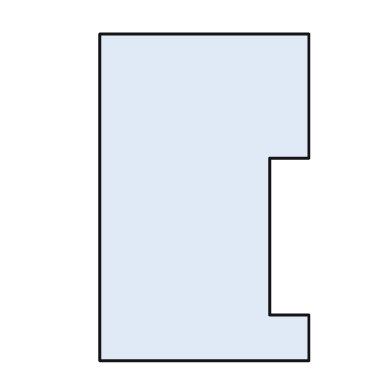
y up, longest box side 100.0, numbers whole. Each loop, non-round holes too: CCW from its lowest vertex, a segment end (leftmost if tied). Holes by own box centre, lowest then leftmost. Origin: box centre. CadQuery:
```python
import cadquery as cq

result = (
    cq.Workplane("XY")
    .moveTo(-32.0, -50.0)
    .lineTo(32.0, -50.0)
    .lineTo(32.0, -36.0)
    .lineTo(20.0, -36.0)
    .lineTo(20.0, 12.0)
    .lineTo(32.0, 12.0)
    .lineTo(32.0, 50.0)
    .lineTo(-32.0, 50.0)
    .close()
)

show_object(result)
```